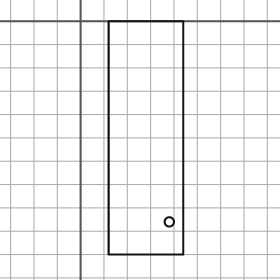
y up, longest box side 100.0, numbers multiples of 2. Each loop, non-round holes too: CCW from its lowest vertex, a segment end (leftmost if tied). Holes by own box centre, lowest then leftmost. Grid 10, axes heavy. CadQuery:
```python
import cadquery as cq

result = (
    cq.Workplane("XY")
    .moveTo(12.0, -100.0)
    .lineTo(44.0, -100.0)
    .lineTo(44.0, 0.0)
    .lineTo(12.0, 0.0)
    .close()
    .moveTo(38.0, -86.0)
    .circle(2.0)
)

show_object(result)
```